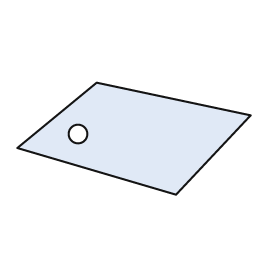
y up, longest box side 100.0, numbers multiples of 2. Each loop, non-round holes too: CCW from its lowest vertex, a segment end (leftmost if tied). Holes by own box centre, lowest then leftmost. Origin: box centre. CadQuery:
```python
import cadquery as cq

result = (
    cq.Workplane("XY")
    .moveTo(18.0, -24.0)
    .lineTo(50.0, 10.0)
    .lineTo(-16.0, 24.0)
    .lineTo(-50.0, -4.0)
    .close()
    .moveTo(-24.0, 2.0)
    .circle(4.0)
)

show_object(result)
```